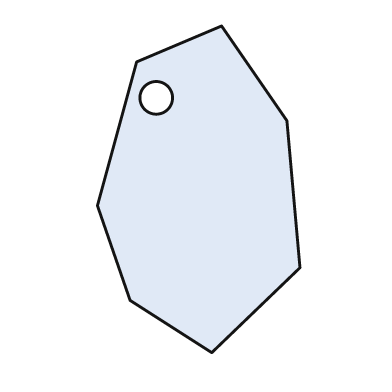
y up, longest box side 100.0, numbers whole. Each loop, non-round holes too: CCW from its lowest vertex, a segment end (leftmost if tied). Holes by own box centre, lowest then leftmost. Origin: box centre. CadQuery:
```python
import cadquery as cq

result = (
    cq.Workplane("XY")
    .moveTo(4.0, -50.0)
    .lineTo(31.0, -24.0)
    .lineTo(27.0, 21.0)
    .lineTo(7.0, 50.0)
    .lineTo(-19.0, 39.0)
    .lineTo(-31.0, -5.0)
    .lineTo(-21.0, -34.0)
    .close()
    .moveTo(-13.0, 28.0)
    .circle(5.0)
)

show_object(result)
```